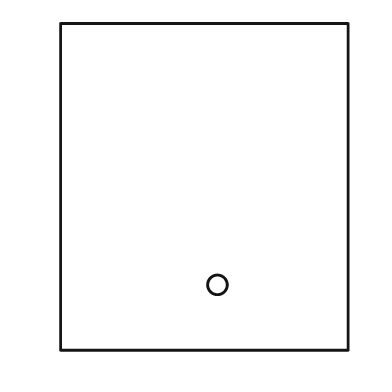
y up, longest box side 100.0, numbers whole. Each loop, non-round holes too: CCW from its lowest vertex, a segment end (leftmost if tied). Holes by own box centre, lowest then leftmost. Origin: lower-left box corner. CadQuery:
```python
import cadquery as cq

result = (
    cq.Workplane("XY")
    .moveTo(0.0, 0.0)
    .lineTo(88.0, 0.0)
    .lineTo(88.0, 100.0)
    .lineTo(0.0, 100.0)
    .close()
    .moveTo(48.0, 20.0)
    .circle(3.0)
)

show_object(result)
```